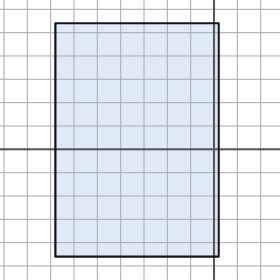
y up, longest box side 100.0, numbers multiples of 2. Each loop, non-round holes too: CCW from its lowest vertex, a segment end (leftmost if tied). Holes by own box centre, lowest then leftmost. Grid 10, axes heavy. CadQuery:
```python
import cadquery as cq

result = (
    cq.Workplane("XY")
    .moveTo(-68.0, -46.0)
    .lineTo(2.0, -46.0)
    .lineTo(2.0, 54.0)
    .lineTo(-68.0, 54.0)
    .close()
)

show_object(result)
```